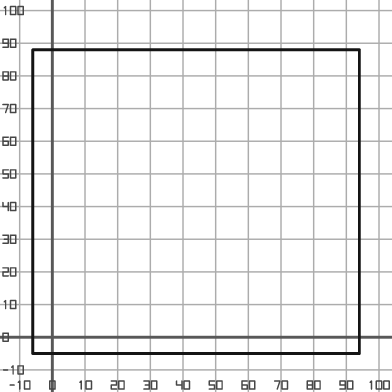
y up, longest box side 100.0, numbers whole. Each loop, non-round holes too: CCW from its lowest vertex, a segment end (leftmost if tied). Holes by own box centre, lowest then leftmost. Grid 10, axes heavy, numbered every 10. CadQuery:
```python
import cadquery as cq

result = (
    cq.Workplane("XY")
    .moveTo(-6.0, -5.0)
    .lineTo(94.0, -5.0)
    .lineTo(94.0, 88.0)
    .lineTo(-6.0, 88.0)
    .close()
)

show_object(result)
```